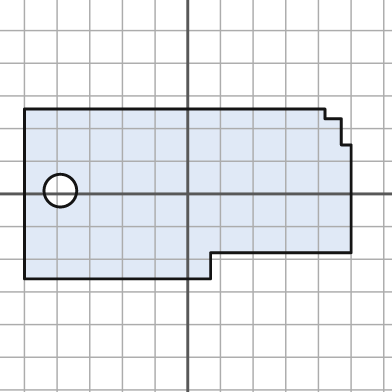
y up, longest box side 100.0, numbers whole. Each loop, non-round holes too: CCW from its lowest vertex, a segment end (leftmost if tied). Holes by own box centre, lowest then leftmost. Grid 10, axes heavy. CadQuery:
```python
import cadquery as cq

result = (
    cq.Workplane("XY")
    .moveTo(-50.0, -26.0)
    .lineTo(7.0, -26.0)
    .lineTo(7.0, -18.0)
    .lineTo(50.0, -18.0)
    .lineTo(50.0, 15.0)
    .lineTo(47.0, 15.0)
    .lineTo(47.0, 23.0)
    .lineTo(42.0, 23.0)
    .lineTo(42.0, 26.0)
    .lineTo(-50.0, 26.0)
    .close()
    .moveTo(-39.0, 1.0)
    .circle(5.0)
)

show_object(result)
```